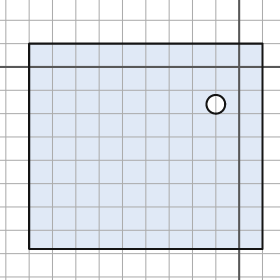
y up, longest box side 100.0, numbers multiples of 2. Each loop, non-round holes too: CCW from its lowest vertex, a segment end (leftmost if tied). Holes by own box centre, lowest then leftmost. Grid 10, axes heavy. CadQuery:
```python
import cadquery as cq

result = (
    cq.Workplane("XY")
    .moveTo(-90.0, -78.0)
    .lineTo(10.0, -78.0)
    .lineTo(10.0, 10.0)
    .lineTo(-90.0, 10.0)
    .close()
    .moveTo(-10.0, -16.0)
    .circle(4.0)
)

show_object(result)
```